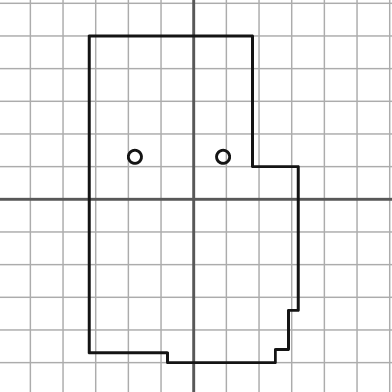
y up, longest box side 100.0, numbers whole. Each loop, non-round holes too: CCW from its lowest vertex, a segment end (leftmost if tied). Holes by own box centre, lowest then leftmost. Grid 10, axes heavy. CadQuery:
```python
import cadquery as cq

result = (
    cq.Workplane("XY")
    .moveTo(-8.0, -50.0)
    .lineTo(25.0, -50.0)
    .lineTo(25.0, -46.0)
    .lineTo(29.0, -46.0)
    .lineTo(29.0, -34.0)
    .lineTo(32.0, -34.0)
    .lineTo(32.0, 10.0)
    .lineTo(18.0, 10.0)
    .lineTo(18.0, 50.0)
    .lineTo(-32.0, 50.0)
    .lineTo(-32.0, -47.0)
    .lineTo(-8.0, -47.0)
    .close()
    .moveTo(-18.0, 13.0)
    .circle(2.0)
    .moveTo(9.0, 13.0)
    .circle(2.0)
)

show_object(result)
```